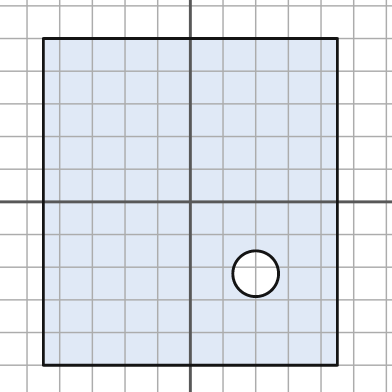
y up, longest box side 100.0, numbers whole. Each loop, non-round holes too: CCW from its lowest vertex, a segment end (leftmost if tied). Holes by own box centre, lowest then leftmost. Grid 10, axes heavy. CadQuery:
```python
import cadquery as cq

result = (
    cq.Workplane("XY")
    .moveTo(-45.0, -50.0)
    .lineTo(45.0, -50.0)
    .lineTo(45.0, 50.0)
    .lineTo(-45.0, 50.0)
    .close()
    .moveTo(20.0, -22.0)
    .circle(7.0)
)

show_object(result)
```